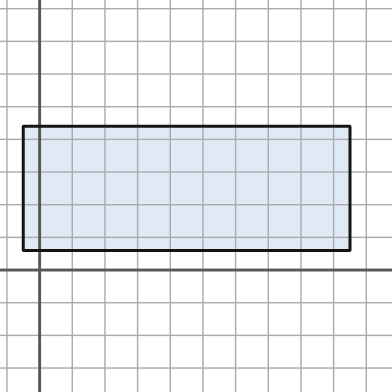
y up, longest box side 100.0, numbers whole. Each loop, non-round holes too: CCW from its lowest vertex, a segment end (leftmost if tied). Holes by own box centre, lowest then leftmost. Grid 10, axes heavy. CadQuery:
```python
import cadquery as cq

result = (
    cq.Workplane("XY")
    .moveTo(-5.0, 6.0)
    .lineTo(95.0, 6.0)
    .lineTo(95.0, 44.0)
    .lineTo(-5.0, 44.0)
    .close()
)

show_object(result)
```